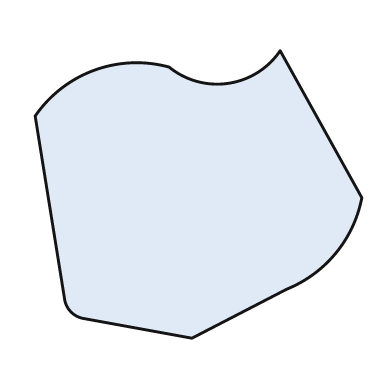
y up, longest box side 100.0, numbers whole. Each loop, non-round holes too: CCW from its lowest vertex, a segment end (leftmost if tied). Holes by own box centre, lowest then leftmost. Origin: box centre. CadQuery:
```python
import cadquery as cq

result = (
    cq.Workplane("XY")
    .moveTo(-2.0, -44.0)
    .lineTo(27.0, -29.0)
    .threePointArc((42.0, -18.0), (50.0, -1.0))
    .lineTo(25.0, 44.0)
    .threePointArc((9.0, 34.0), (-9.0, 39.0))
    .threePointArc((-32.0, 38.0), (-50.0, 24.0))
    .lineTo(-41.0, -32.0)
    .threePointArc((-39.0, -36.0), (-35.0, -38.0))
    .close()
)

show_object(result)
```